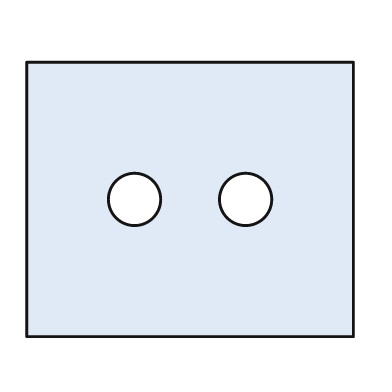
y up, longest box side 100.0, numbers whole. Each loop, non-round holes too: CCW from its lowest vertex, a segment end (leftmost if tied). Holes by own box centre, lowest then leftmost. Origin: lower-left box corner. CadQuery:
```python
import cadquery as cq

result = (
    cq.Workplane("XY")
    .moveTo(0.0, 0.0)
    .lineTo(100.0, 0.0)
    .lineTo(100.0, 84.0)
    .lineTo(0.0, 84.0)
    .close()
    .moveTo(33.0, 42.0)
    .circle(8.0)
    .moveTo(67.0, 42.0)
    .circle(8.0)
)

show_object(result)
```